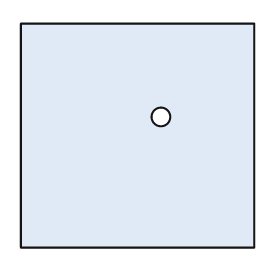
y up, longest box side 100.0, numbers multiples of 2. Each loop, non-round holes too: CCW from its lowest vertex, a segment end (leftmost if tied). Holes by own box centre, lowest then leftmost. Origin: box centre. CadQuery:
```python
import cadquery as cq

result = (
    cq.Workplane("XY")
    .moveTo(-50.0, -48.0)
    .lineTo(50.0, -48.0)
    .lineTo(50.0, 48.0)
    .lineTo(-50.0, 48.0)
    .close()
    .moveTo(10.0, 8.0)
    .circle(4.0)
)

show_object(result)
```